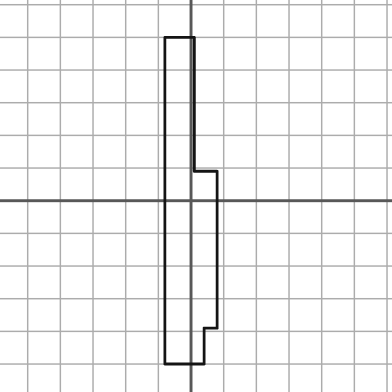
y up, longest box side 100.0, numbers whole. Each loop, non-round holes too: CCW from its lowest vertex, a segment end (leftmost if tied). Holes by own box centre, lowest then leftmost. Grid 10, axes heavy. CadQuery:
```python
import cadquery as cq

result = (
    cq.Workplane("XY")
    .moveTo(-8.0, -50.0)
    .lineTo(4.0, -50.0)
    .lineTo(4.0, -39.0)
    .lineTo(8.0, -39.0)
    .lineTo(8.0, 9.0)
    .lineTo(1.0, 9.0)
    .lineTo(1.0, 50.0)
    .lineTo(-8.0, 50.0)
    .close()
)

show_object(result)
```